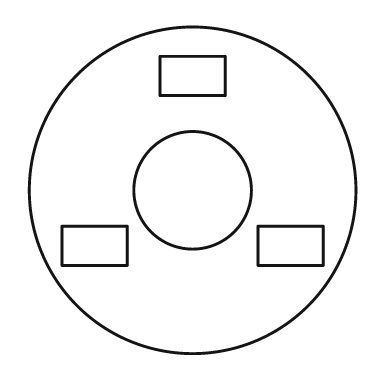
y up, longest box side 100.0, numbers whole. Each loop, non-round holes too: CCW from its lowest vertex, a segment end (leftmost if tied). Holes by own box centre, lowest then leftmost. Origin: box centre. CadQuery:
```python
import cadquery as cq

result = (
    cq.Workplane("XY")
    .moveTo(0.0, 0.0)
    .circle(50.0)
    .moveTo(-40.0, -23.0)
    .lineTo(-20.0, -23.0)
    .lineTo(-20.0, -11.0)
    .lineTo(-40.0, -11.0)
    .close()
    .moveTo(20.0, -23.0)
    .lineTo(40.0, -23.0)
    .lineTo(40.0, -11.0)
    .lineTo(20.0, -11.0)
    .close()
    .moveTo(0.0, 0.0)
    .circle(18.0)
    .moveTo(-10.0, 29.0)
    .lineTo(10.0, 29.0)
    .lineTo(10.0, 41.0)
    .lineTo(-10.0, 41.0)
    .close()
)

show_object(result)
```